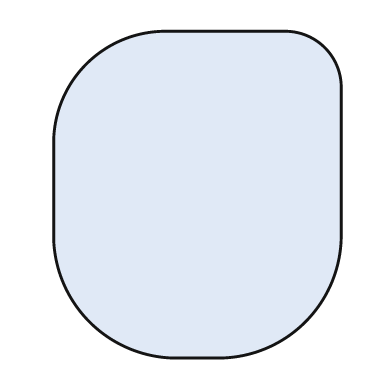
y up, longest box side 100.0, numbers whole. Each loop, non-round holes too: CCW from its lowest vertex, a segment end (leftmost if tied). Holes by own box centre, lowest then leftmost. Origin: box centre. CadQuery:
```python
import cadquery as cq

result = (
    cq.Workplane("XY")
    .moveTo(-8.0, -50.0)
    .lineTo(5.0, -50.0)
    .threePointArc((33.0, -39.0), (44.0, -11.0))
    .lineTo(44.0, 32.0)
    .threePointArc((39.0, 45.0), (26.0, 50.0))
    .lineTo(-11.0, 50.0)
    .threePointArc((-34.0, 40.0), (-44.0, 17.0))
    .lineTo(-44.0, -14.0)
    .threePointArc((-33.0, -39.0), (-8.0, -50.0))
    .close()
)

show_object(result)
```